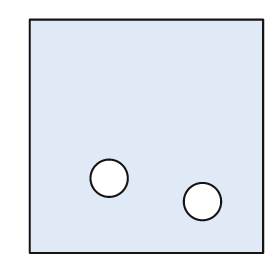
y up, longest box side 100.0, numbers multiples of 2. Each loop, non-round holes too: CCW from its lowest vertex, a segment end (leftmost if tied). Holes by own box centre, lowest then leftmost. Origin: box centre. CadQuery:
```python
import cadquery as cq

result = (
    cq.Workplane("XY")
    .moveTo(-50.0, -50.0)
    .lineTo(50.0, -50.0)
    .lineTo(50.0, 50.0)
    .lineTo(-50.0, 50.0)
    .close()
    .moveTo(24.0, -28.0)
    .circle(8.0)
    .moveTo(-16.0, -18.0)
    .circle(8.0)
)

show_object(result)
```